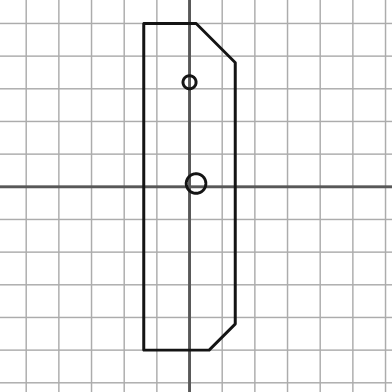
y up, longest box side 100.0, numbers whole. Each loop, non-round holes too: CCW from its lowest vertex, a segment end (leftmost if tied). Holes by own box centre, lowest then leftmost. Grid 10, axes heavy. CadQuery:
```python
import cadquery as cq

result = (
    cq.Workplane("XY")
    .moveTo(-14.0, -50.0)
    .lineTo(6.0, -50.0)
    .lineTo(14.0, -42.0)
    .lineTo(14.0, 38.0)
    .lineTo(2.0, 50.0)
    .lineTo(-14.0, 50.0)
    .close()
    .moveTo(2.0, 1.0)
    .circle(3.0)
    .moveTo(0.0, 32.0)
    .circle(2.0)
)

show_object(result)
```